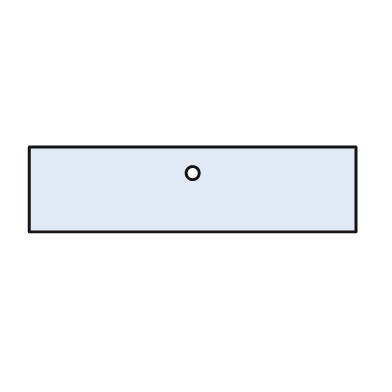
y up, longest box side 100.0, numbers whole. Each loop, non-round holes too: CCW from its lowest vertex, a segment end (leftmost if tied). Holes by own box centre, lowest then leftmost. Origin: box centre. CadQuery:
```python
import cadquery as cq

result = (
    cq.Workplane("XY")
    .moveTo(-50.0, -13.0)
    .lineTo(50.0, -13.0)
    .lineTo(50.0, 13.0)
    .lineTo(-50.0, 13.0)
    .close()
    .moveTo(0.0, 5.0)
    .circle(2.0)
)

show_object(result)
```